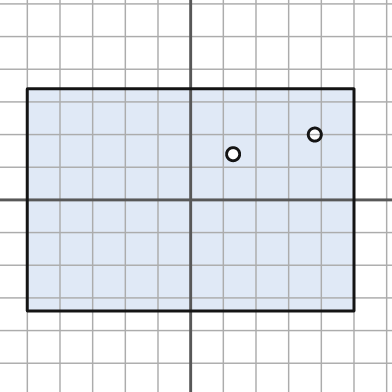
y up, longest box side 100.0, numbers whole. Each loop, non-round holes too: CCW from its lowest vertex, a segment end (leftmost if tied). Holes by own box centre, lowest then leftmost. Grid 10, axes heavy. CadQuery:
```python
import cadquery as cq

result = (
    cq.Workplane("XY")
    .moveTo(-50.0, -34.0)
    .lineTo(50.0, -34.0)
    .lineTo(50.0, 34.0)
    .lineTo(-50.0, 34.0)
    .close()
    .moveTo(13.0, 14.0)
    .circle(2.0)
    .moveTo(38.0, 20.0)
    .circle(2.0)
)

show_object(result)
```